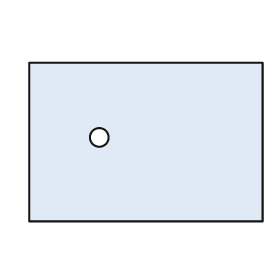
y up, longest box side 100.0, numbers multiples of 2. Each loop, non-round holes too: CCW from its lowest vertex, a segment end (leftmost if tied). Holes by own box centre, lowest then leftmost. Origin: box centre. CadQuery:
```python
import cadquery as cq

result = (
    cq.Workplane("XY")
    .moveTo(-50.0, -34.0)
    .lineTo(50.0, -34.0)
    .lineTo(50.0, 34.0)
    .lineTo(-50.0, 34.0)
    .close()
    .moveTo(-20.0, 2.0)
    .circle(4.0)
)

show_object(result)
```